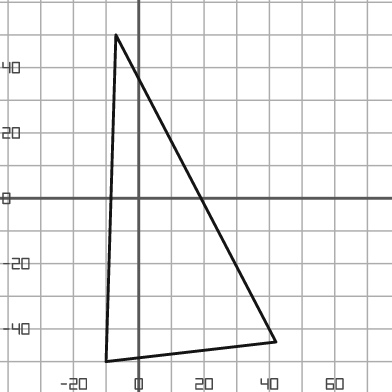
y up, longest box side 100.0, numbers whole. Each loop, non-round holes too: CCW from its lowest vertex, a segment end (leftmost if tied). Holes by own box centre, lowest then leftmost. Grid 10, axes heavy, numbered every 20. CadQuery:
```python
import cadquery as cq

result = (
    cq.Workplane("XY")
    .moveTo(-10.0, -50.0)
    .lineTo(42.0, -44.0)
    .lineTo(-7.0, 50.0)
    .close()
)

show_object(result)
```